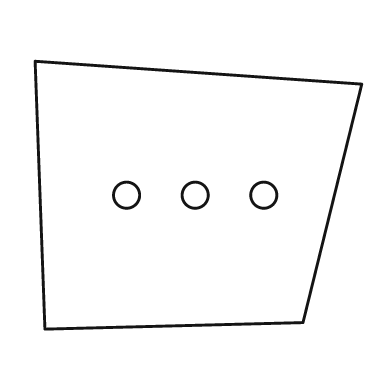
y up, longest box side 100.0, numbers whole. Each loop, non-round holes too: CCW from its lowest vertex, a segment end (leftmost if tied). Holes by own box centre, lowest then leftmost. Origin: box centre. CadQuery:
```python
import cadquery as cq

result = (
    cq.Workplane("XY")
    .moveTo(-47.0, -41.0)
    .lineTo(32.0, -39.0)
    .lineTo(50.0, 34.0)
    .lineTo(-50.0, 41.0)
    .close()
    .moveTo(-22.0, 0.0)
    .circle(4.0)
    .moveTo(-1.0, 0.0)
    .circle(4.0)
    .moveTo(20.0, 0.0)
    .circle(4.0)
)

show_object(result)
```